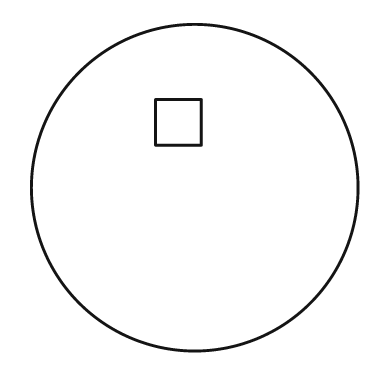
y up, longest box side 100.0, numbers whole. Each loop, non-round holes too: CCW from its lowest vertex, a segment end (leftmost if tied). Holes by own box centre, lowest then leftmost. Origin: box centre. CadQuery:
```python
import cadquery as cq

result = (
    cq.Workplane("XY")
    .moveTo(0.0, 0.0)
    .circle(50.0)
    .moveTo(-12.0, 13.0)
    .lineTo(2.0, 13.0)
    .lineTo(2.0, 27.0)
    .lineTo(-12.0, 27.0)
    .close()
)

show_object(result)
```